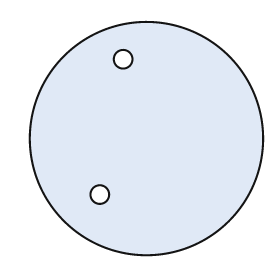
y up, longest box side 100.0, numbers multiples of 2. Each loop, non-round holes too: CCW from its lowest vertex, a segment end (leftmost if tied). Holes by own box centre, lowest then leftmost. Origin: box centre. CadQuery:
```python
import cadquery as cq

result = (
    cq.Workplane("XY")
    .moveTo(0.0, 0.0)
    .circle(50.0)
    .moveTo(-20.0, -24.0)
    .circle(4.0)
    .moveTo(-10.0, 34.0)
    .circle(4.0)
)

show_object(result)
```